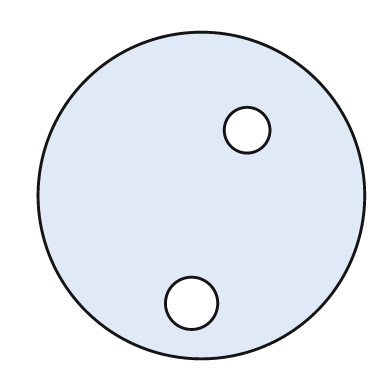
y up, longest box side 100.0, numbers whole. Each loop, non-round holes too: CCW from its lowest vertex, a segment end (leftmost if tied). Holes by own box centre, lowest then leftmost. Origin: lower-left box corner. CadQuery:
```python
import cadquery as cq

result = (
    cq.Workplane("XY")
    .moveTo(50.0, 50.0)
    .circle(50.0)
    .moveTo(47.0, 17.0)
    .circle(8.0)
    .moveTo(64.0, 70.0)
    .circle(7.0)
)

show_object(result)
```